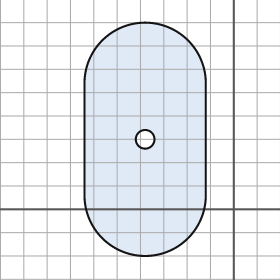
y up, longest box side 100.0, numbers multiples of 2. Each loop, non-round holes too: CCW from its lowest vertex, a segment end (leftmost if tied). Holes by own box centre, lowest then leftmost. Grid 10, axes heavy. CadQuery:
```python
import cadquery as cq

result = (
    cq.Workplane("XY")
    .moveTo(-64.0, 6.0)
    .threePointArc((-38.0, -20.0), (-12.0, 6.0))
    .lineTo(-12.0, 54.0)
    .threePointArc((-38.0, 80.0), (-64.0, 54.0))
    .close()
    .moveTo(-38.0, 30.0)
    .circle(4.0)
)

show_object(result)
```